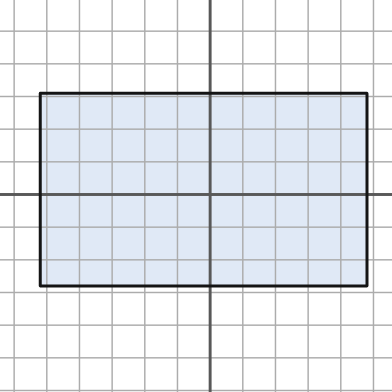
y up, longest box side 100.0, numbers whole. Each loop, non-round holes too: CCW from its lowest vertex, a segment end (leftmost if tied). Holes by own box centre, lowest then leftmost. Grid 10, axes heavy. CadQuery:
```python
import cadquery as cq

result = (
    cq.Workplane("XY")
    .moveTo(-52.0, -28.0)
    .lineTo(48.0, -28.0)
    .lineTo(48.0, 31.0)
    .lineTo(-52.0, 31.0)
    .close()
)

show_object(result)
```